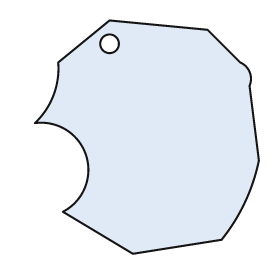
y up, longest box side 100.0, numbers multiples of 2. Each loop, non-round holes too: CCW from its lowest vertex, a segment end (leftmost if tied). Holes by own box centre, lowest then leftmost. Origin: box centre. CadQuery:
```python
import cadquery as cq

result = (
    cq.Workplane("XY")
    .moveTo(-6.0, -50.0)
    .lineTo(32.0, -44.0)
    .threePointArc((42.0, -28.0), (48.0, -10.0))
    .lineTo(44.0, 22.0)
    .threePointArc((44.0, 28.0), (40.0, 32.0))
    .lineTo(26.0, 46.0)
    .lineTo(-16.0, 50.0)
    .lineTo(-38.0, 32.0)
    .threePointArc((-40.0, 18.0), (-48.0, 6.0))
    .threePointArc((-26.0, -8.0), (-36.0, -32.0))
    .close()
    .moveTo(-16.0, 40.0)
    .circle(4.0)
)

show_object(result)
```